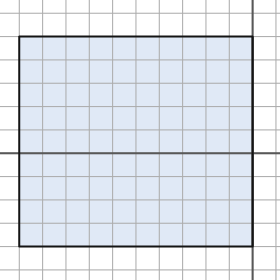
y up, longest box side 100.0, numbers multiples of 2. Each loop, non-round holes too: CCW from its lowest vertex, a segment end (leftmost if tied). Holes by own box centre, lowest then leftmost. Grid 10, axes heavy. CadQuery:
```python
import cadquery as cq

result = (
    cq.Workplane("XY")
    .moveTo(-100.0, -40.0)
    .lineTo(0.0, -40.0)
    .lineTo(0.0, 50.0)
    .lineTo(-100.0, 50.0)
    .close()
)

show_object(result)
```